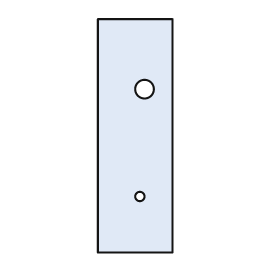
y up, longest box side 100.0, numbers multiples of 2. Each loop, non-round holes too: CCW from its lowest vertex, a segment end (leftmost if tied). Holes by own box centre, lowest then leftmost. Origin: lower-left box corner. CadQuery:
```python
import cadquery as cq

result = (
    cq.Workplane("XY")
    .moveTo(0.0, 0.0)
    .lineTo(32.0, 0.0)
    .lineTo(32.0, 100.0)
    .lineTo(0.0, 100.0)
    .close()
    .moveTo(18.0, 24.0)
    .circle(2.0)
    .moveTo(20.0, 70.0)
    .circle(4.0)
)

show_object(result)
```